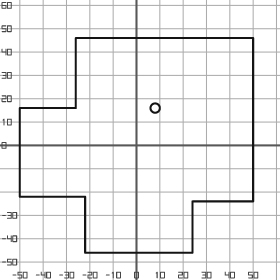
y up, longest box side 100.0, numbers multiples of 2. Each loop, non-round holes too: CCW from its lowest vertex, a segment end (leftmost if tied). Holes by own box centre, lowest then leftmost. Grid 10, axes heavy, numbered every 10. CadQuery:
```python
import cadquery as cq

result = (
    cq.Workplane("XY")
    .moveTo(-22.0, -46.0)
    .lineTo(24.0, -46.0)
    .lineTo(24.0, -24.0)
    .lineTo(50.0, -24.0)
    .lineTo(50.0, 46.0)
    .lineTo(-26.0, 46.0)
    .lineTo(-26.0, 16.0)
    .lineTo(-50.0, 16.0)
    .lineTo(-50.0, -22.0)
    .lineTo(-22.0, -22.0)
    .close()
    .moveTo(8.0, 16.0)
    .circle(2.0)
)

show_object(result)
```